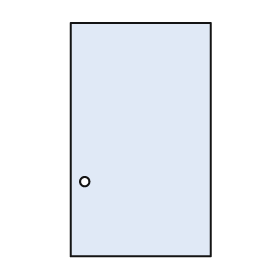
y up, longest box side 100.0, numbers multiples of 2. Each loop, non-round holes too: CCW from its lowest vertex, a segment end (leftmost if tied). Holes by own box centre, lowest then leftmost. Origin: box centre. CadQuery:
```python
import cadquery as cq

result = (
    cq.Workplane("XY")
    .moveTo(-30.0, -50.0)
    .lineTo(30.0, -50.0)
    .lineTo(30.0, 50.0)
    .lineTo(-30.0, 50.0)
    .close()
    .moveTo(-24.0, -18.0)
    .circle(2.0)
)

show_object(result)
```